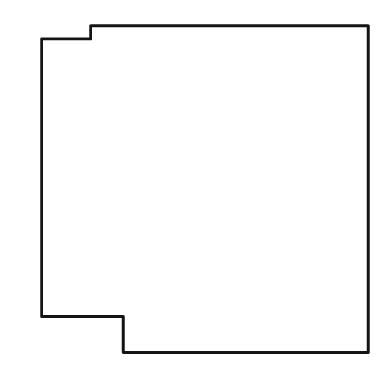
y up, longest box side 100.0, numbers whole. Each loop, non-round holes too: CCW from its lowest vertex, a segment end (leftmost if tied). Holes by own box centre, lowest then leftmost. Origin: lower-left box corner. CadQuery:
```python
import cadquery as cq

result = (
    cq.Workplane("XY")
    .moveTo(25.0, 0.0)
    .lineTo(100.0, 0.0)
    .lineTo(100.0, 100.0)
    .lineTo(15.0, 100.0)
    .lineTo(15.0, 96.0)
    .lineTo(0.0, 96.0)
    .lineTo(0.0, 11.0)
    .lineTo(25.0, 11.0)
    .close()
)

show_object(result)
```